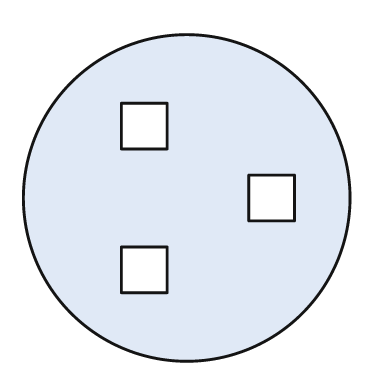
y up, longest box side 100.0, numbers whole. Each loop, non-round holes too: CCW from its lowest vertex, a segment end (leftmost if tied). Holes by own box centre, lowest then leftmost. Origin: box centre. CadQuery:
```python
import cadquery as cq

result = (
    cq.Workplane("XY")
    .moveTo(0.0, 0.0)
    .circle(50.0)
    .moveTo(-20.0, -29.0)
    .lineTo(-6.0, -29.0)
    .lineTo(-6.0, -15.0)
    .lineTo(-20.0, -15.0)
    .close()
    .moveTo(19.0, -7.0)
    .lineTo(33.0, -7.0)
    .lineTo(33.0, 7.0)
    .lineTo(19.0, 7.0)
    .close()
    .moveTo(-20.0, 15.0)
    .lineTo(-6.0, 15.0)
    .lineTo(-6.0, 29.0)
    .lineTo(-20.0, 29.0)
    .close()
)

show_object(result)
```